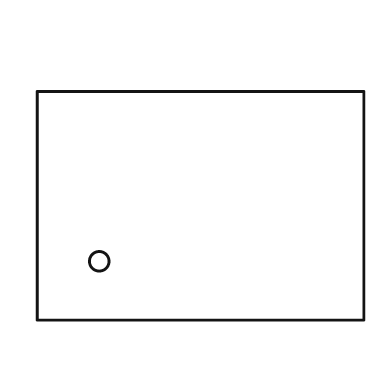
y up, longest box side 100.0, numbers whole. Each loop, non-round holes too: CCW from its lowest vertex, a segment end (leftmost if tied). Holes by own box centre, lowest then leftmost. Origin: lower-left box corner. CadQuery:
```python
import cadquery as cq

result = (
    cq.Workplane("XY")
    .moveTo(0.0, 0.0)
    .lineTo(100.0, 0.0)
    .lineTo(100.0, 70.0)
    .lineTo(0.0, 70.0)
    .close()
    .moveTo(19.0, 18.0)
    .circle(3.0)
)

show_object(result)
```